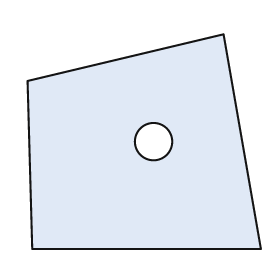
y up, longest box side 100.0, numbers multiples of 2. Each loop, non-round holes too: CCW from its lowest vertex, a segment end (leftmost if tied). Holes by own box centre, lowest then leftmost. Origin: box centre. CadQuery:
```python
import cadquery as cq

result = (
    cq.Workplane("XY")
    .moveTo(-48.0, -46.0)
    .lineTo(50.0, -46.0)
    .lineTo(34.0, 46.0)
    .lineTo(-50.0, 26.0)
    .close()
    .moveTo(4.0, 0.0)
    .circle(8.0)
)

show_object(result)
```